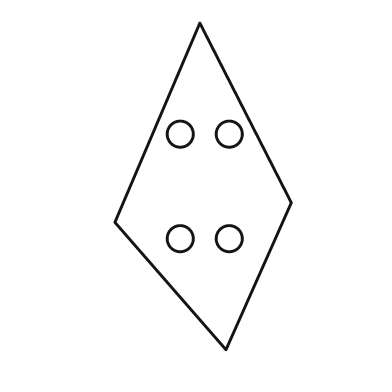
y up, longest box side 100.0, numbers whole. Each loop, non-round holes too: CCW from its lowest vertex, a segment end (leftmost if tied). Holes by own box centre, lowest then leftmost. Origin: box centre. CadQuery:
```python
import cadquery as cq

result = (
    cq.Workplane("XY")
    .moveTo(7.0, -50.0)
    .lineTo(27.0, -5.0)
    .lineTo(-1.0, 50.0)
    .lineTo(-27.0, -11.0)
    .close()
    .moveTo(-7.0, -16.0)
    .circle(4.0)
    .moveTo(8.0, -16.0)
    .circle(4.0)
    .moveTo(-7.0, 16.0)
    .circle(4.0)
    .moveTo(8.0, 16.0)
    .circle(4.0)
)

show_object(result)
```